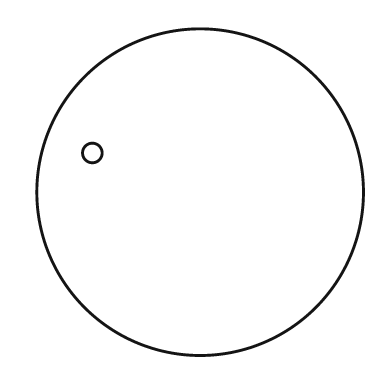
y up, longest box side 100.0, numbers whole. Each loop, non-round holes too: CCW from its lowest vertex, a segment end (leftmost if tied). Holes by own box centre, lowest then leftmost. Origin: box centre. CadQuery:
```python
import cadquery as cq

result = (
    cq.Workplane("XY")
    .moveTo(0.0, 0.0)
    .circle(50.0)
    .moveTo(-33.0, 12.0)
    .circle(3.0)
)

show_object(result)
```